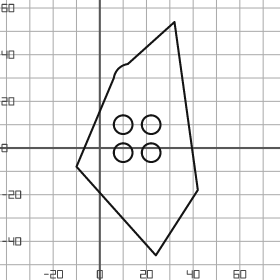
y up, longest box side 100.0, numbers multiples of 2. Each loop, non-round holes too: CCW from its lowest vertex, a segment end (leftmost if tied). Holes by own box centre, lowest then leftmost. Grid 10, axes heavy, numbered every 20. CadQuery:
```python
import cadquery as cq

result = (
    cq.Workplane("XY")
    .moveTo(24.0, -46.0)
    .lineTo(42.0, -18.0)
    .lineTo(32.0, 54.0)
    .lineTo(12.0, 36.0)
    .threePointArc((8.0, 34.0), (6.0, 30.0))
    .lineTo(-10.0, -8.0)
    .close()
    .moveTo(10.0, -2.0)
    .circle(4.0)
    .moveTo(22.0, -2.0)
    .circle(4.0)
    .moveTo(10.0, 10.0)
    .circle(4.0)
    .moveTo(22.0, 10.0)
    .circle(4.0)
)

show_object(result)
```